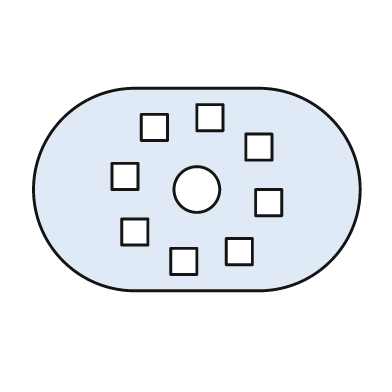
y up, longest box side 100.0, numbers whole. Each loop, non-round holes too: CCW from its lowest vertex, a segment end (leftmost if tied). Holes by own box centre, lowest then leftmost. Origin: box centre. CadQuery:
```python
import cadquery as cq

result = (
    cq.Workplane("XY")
    .moveTo(-19.0, -31.0)
    .lineTo(19.0, -31.0)
    .threePointArc((50.0, 0.0), (19.0, 31.0))
    .lineTo(-19.0, 31.0)
    .threePointArc((-50.0, 0.0), (-19.0, -31.0))
    .close()
    .moveTo(-8.0, -26.0)
    .lineTo(0.0, -26.0)
    .lineTo(0.0, -18.0)
    .lineTo(-8.0, -18.0)
    .close()
    .moveTo(9.0, -23.0)
    .lineTo(17.0, -23.0)
    .lineTo(17.0, -15.0)
    .lineTo(9.0, -15.0)
    .close()
    .moveTo(-23.0, -17.0)
    .lineTo(-15.0, -17.0)
    .lineTo(-15.0, -9.0)
    .lineTo(-23.0, -9.0)
    .close()
    .moveTo(18.0, -8.0)
    .lineTo(26.0, -8.0)
    .lineTo(26.0, 0.0)
    .lineTo(18.0, 0.0)
    .close()
    .moveTo(0.0, 0.0)
    .circle(7.0)
    .moveTo(-26.0, 0.0)
    .lineTo(-18.0, 0.0)
    .lineTo(-18.0, 8.0)
    .lineTo(-26.0, 8.0)
    .close()
    .moveTo(15.0, 9.0)
    .lineTo(23.0, 9.0)
    .lineTo(23.0, 17.0)
    .lineTo(15.0, 17.0)
    .close()
    .moveTo(-17.0, 15.0)
    .lineTo(-9.0, 15.0)
    .lineTo(-9.0, 23.0)
    .lineTo(-17.0, 23.0)
    .close()
    .moveTo(0.0, 18.0)
    .lineTo(8.0, 18.0)
    .lineTo(8.0, 26.0)
    .lineTo(0.0, 26.0)
    .close()
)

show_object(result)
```